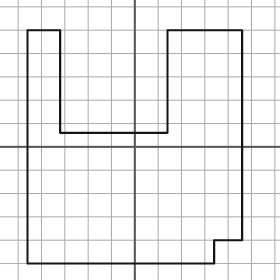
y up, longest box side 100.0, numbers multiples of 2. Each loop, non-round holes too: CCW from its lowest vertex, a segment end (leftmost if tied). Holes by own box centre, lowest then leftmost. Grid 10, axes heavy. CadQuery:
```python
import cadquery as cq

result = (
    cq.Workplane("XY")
    .moveTo(-46.0, -50.0)
    .lineTo(34.0, -50.0)
    .lineTo(34.0, -40.0)
    .lineTo(46.0, -40.0)
    .lineTo(46.0, 50.0)
    .lineTo(14.0, 50.0)
    .lineTo(14.0, 6.0)
    .lineTo(-32.0, 6.0)
    .lineTo(-32.0, 50.0)
    .lineTo(-46.0, 50.0)
    .close()
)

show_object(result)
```